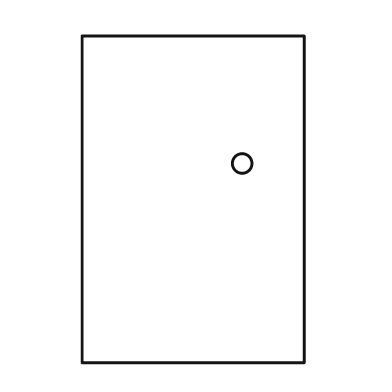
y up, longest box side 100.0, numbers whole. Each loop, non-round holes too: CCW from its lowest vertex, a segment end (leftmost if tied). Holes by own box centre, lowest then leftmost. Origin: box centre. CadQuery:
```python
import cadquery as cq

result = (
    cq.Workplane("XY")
    .moveTo(-34.0, -50.0)
    .lineTo(34.0, -50.0)
    .lineTo(34.0, 50.0)
    .lineTo(-34.0, 50.0)
    .close()
    .moveTo(15.0, 11.0)
    .circle(3.0)
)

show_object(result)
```